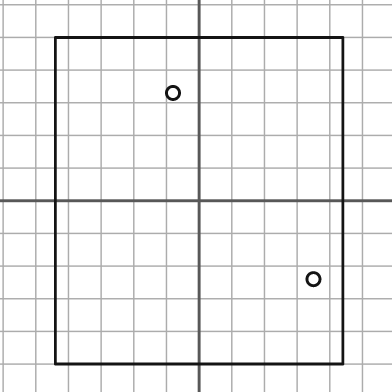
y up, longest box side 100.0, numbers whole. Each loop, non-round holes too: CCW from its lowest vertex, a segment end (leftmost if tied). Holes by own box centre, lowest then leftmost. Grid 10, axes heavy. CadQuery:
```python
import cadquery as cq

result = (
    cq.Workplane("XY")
    .moveTo(-44.0, -50.0)
    .lineTo(44.0, -50.0)
    .lineTo(44.0, 50.0)
    .lineTo(-44.0, 50.0)
    .close()
    .moveTo(35.0, -24.0)
    .circle(2.0)
    .moveTo(-8.0, 33.0)
    .circle(2.0)
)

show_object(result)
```